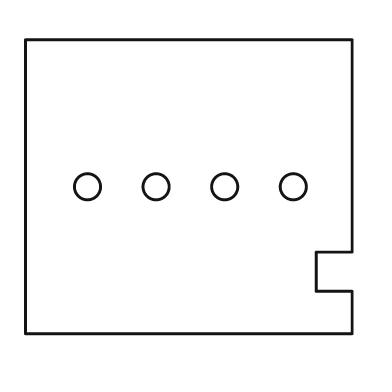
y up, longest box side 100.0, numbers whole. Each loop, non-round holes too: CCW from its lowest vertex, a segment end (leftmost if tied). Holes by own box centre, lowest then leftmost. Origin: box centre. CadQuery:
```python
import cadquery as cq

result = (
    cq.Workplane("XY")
    .moveTo(-50.0, -45.0)
    .lineTo(50.0, -45.0)
    .lineTo(50.0, -32.0)
    .lineTo(39.0, -32.0)
    .lineTo(39.0, -20.0)
    .lineTo(50.0, -20.0)
    .lineTo(50.0, 45.0)
    .lineTo(-50.0, 45.0)
    .close()
    .moveTo(-31.0, 0.0)
    .circle(4.0)
    .moveTo(-10.0, 0.0)
    .circle(4.0)
    .moveTo(11.0, 0.0)
    .circle(4.0)
    .moveTo(32.0, 0.0)
    .circle(4.0)
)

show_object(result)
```